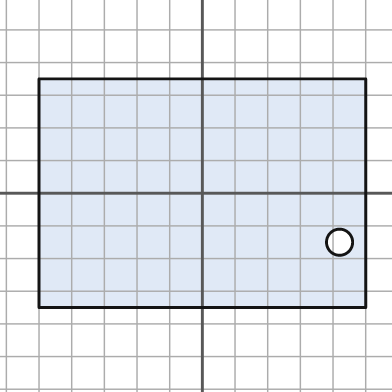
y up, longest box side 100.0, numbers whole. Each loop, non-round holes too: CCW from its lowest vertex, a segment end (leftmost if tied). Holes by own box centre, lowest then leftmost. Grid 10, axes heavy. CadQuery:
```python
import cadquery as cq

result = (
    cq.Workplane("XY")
    .moveTo(-50.0, -35.0)
    .lineTo(50.0, -35.0)
    .lineTo(50.0, 35.0)
    .lineTo(-50.0, 35.0)
    .close()
    .moveTo(42.0, -15.0)
    .circle(4.0)
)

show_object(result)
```